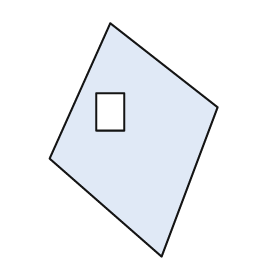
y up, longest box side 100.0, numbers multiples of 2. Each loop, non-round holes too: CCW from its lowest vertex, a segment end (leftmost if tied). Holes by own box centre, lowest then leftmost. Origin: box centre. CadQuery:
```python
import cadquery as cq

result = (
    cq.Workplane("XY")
    .moveTo(12.0, -50.0)
    .lineTo(36.0, 14.0)
    .lineTo(-10.0, 50.0)
    .lineTo(-36.0, -8.0)
    .close()
    .moveTo(-16.0, 4.0)
    .lineTo(-4.0, 4.0)
    .lineTo(-4.0, 20.0)
    .lineTo(-16.0, 20.0)
    .close()
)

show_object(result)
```